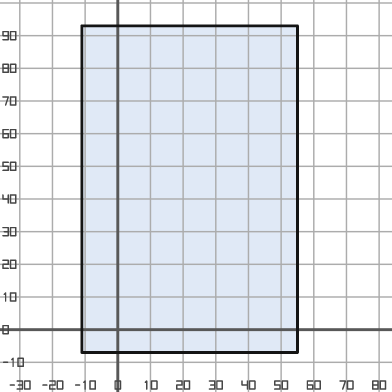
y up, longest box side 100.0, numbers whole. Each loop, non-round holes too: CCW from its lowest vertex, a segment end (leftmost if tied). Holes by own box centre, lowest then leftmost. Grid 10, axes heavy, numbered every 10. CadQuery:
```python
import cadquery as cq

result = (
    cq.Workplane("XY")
    .moveTo(-11.0, -7.0)
    .lineTo(55.0, -7.0)
    .lineTo(55.0, 93.0)
    .lineTo(-11.0, 93.0)
    .close()
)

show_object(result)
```